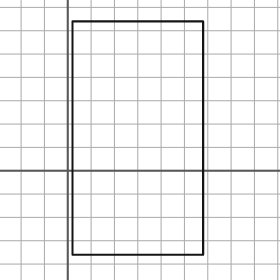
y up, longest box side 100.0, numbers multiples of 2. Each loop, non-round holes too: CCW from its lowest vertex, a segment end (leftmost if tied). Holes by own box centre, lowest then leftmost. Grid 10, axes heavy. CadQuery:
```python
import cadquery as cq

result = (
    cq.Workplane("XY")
    .moveTo(2.0, -36.0)
    .lineTo(58.0, -36.0)
    .lineTo(58.0, 64.0)
    .lineTo(2.0, 64.0)
    .close()
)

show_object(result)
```